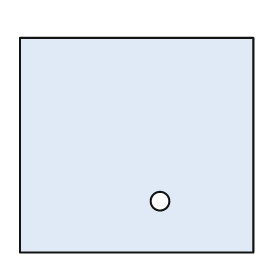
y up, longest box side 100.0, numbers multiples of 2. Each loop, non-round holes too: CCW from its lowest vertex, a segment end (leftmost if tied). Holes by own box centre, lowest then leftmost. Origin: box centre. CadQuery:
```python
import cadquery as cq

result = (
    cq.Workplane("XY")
    .moveTo(-50.0, -46.0)
    .lineTo(50.0, -46.0)
    .lineTo(50.0, 46.0)
    .lineTo(-50.0, 46.0)
    .close()
    .moveTo(10.0, -24.0)
    .circle(4.0)
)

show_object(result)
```